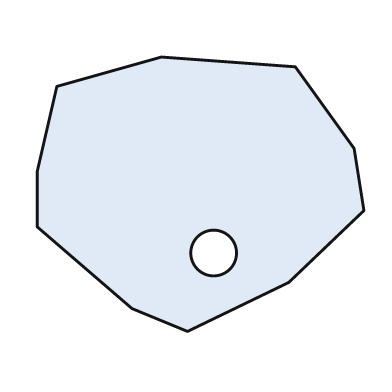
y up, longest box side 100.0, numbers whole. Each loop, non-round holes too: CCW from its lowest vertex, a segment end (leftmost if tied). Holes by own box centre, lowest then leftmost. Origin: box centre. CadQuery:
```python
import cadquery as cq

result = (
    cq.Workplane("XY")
    .moveTo(-4.0, -42.0)
    .lineTo(27.0, -27.0)
    .lineTo(50.0, -5.0)
    .lineTo(47.0, 14.0)
    .lineTo(29.0, 39.0)
    .lineTo(-12.0, 42.0)
    .lineTo(-44.0, 33.0)
    .lineTo(-50.0, 7.0)
    .lineTo(-50.0, -10.0)
    .lineTo(-21.0, -35.0)
    .close()
    .moveTo(4.0, -18.0)
    .circle(7.0)
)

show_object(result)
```